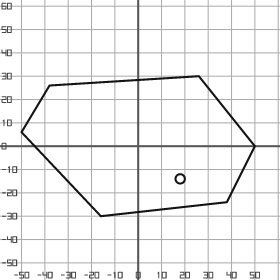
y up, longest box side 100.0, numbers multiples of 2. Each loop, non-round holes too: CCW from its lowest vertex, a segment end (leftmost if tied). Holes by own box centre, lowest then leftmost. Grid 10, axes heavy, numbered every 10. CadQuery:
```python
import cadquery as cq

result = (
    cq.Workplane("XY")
    .moveTo(-16.0, -30.0)
    .lineTo(38.0, -24.0)
    .lineTo(50.0, 0.0)
    .lineTo(26.0, 30.0)
    .lineTo(-38.0, 26.0)
    .lineTo(-50.0, 6.0)
    .close()
    .moveTo(18.0, -14.0)
    .circle(2.0)
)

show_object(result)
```